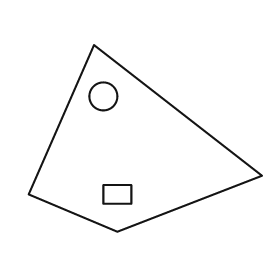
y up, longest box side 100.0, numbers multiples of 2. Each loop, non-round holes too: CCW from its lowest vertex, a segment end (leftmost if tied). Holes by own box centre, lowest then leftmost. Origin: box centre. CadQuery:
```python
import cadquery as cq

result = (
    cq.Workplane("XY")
    .moveTo(-12.0, -40.0)
    .lineTo(50.0, -16.0)
    .lineTo(-22.0, 40.0)
    .lineTo(-50.0, -24.0)
    .close()
    .moveTo(-18.0, -28.0)
    .lineTo(-6.0, -28.0)
    .lineTo(-6.0, -20.0)
    .lineTo(-18.0, -20.0)
    .close()
    .moveTo(-18.0, 18.0)
    .circle(6.0)
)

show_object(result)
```